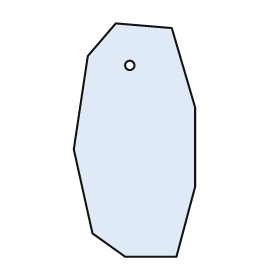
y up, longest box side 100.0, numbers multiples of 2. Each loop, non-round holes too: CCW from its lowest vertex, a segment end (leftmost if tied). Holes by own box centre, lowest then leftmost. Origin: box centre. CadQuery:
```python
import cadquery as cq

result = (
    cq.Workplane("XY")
    .moveTo(-4.0, -50.0)
    .lineTo(18.0, -50.0)
    .lineTo(26.0, -20.0)
    .lineTo(26.0, 14.0)
    .lineTo(16.0, 48.0)
    .lineTo(-8.0, 50.0)
    .lineTo(-20.0, 36.0)
    .lineTo(-26.0, -4.0)
    .lineTo(-18.0, -40.0)
    .close()
    .moveTo(-2.0, 32.0)
    .circle(2.0)
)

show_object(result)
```